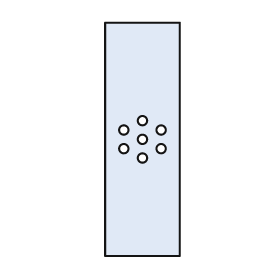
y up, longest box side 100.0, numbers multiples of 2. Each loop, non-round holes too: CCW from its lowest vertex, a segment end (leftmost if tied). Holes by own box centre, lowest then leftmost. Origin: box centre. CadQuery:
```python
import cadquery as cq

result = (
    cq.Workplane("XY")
    .moveTo(-16.0, -50.0)
    .lineTo(16.0, -50.0)
    .lineTo(16.0, 50.0)
    .lineTo(-16.0, 50.0)
    .close()
    .moveTo(0.0, -8.0)
    .circle(2.0)
    .moveTo(-8.0, -4.0)
    .circle(2.0)
    .moveTo(8.0, -4.0)
    .circle(2.0)
    .moveTo(0.0, 0.0)
    .circle(2.0)
    .moveTo(-8.0, 4.0)
    .circle(2.0)
    .moveTo(8.0, 4.0)
    .circle(2.0)
    .moveTo(0.0, 8.0)
    .circle(2.0)
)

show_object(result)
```